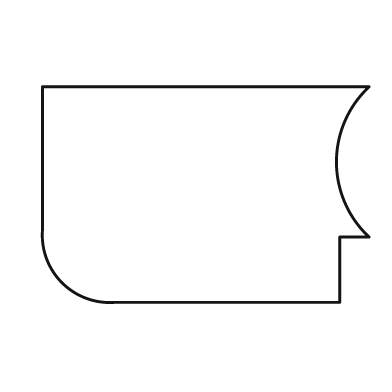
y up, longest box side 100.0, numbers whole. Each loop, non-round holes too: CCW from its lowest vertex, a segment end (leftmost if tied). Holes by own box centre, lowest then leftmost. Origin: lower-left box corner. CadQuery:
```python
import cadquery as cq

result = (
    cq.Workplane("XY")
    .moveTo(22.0, 0.0)
    .lineTo(91.0, 0.0)
    .lineTo(91.0, 20.0)
    .lineTo(100.0, 20.0)
    .threePointArc((90.0, 43.0), (100.0, 66.0))
    .lineTo(0.0, 66.0)
    .lineTo(0.0, 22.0)
    .threePointArc((6.0, 6.0), (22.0, 0.0))
    .close()
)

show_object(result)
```